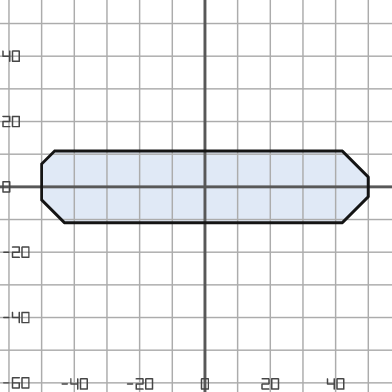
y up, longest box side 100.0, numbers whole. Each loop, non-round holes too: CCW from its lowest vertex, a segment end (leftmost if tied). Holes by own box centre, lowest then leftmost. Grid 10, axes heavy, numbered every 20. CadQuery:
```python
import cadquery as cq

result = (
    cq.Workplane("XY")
    .moveTo(-43.0, -11.0)
    .lineTo(42.0, -11.0)
    .lineTo(50.0, -3.0)
    .lineTo(50.0, 3.0)
    .lineTo(42.0, 11.0)
    .lineTo(-46.0, 11.0)
    .lineTo(-50.0, 7.0)
    .lineTo(-50.0, -4.0)
    .close()
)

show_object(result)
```